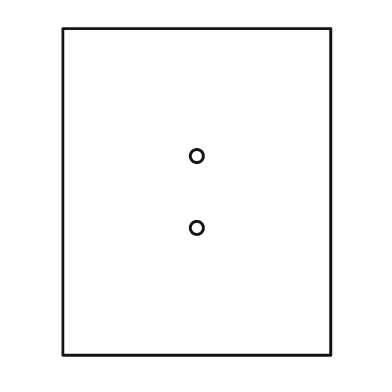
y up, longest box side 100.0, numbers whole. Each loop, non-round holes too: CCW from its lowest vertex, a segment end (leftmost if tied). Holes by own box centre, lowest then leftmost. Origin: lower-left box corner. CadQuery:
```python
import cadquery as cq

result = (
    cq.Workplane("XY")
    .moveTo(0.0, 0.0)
    .lineTo(82.0, 0.0)
    .lineTo(82.0, 100.0)
    .lineTo(0.0, 100.0)
    .close()
    .moveTo(41.0, 39.0)
    .circle(2.0)
    .moveTo(41.0, 61.0)
    .circle(2.0)
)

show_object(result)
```